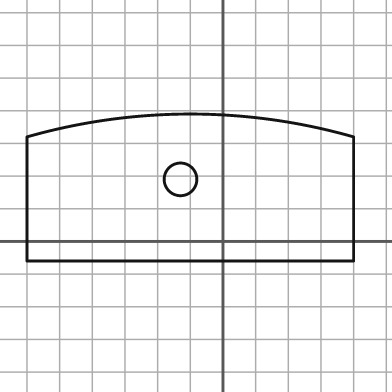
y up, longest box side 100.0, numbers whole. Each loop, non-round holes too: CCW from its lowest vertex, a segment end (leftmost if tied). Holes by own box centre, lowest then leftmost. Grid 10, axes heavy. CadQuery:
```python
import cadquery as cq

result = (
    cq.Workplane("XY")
    .moveTo(-60.0, -6.0)
    .lineTo(40.0, -6.0)
    .lineTo(40.0, 32.0)
    .threePointArc((-10.0, 39.0), (-60.0, 32.0))
    .close()
    .moveTo(-13.0, 19.0)
    .circle(5.0)
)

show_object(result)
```